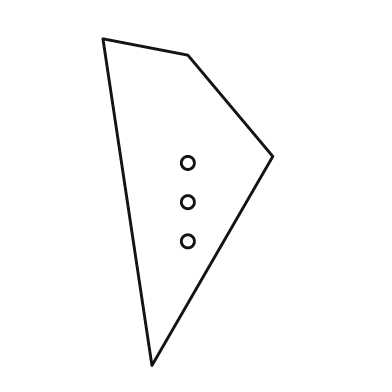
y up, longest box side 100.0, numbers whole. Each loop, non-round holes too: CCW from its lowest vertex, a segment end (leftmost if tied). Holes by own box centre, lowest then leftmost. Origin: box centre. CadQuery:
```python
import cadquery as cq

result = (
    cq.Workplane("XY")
    .moveTo(-11.0, -50.0)
    .lineTo(26.0, 14.0)
    .lineTo(0.0, 45.0)
    .lineTo(-26.0, 50.0)
    .close()
    .moveTo(0.0, -12.0)
    .circle(2.0)
    .moveTo(0.0, 0.0)
    .circle(2.0)
    .moveTo(0.0, 12.0)
    .circle(2.0)
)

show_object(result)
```